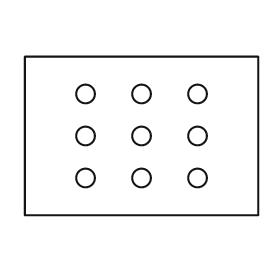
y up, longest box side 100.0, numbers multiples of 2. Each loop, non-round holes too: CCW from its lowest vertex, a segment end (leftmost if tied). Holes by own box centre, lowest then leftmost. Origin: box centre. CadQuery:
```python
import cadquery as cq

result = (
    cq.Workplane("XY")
    .moveTo(-50.0, -34.0)
    .lineTo(50.0, -34.0)
    .lineTo(50.0, 34.0)
    .lineTo(-50.0, 34.0)
    .close()
    .moveTo(-24.0, -18.0)
    .circle(4.0)
    .moveTo(0.0, -18.0)
    .circle(4.0)
    .moveTo(24.0, -18.0)
    .circle(4.0)
    .moveTo(-24.0, 0.0)
    .circle(4.0)
    .moveTo(0.0, 0.0)
    .circle(4.0)
    .moveTo(24.0, 0.0)
    .circle(4.0)
    .moveTo(-24.0, 18.0)
    .circle(4.0)
    .moveTo(0.0, 18.0)
    .circle(4.0)
    .moveTo(24.0, 18.0)
    .circle(4.0)
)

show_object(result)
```